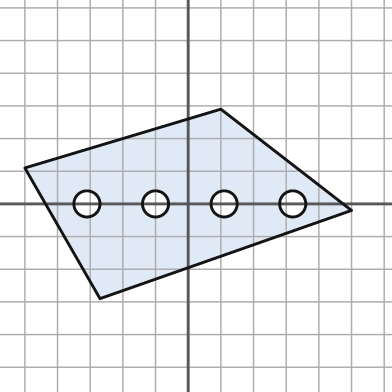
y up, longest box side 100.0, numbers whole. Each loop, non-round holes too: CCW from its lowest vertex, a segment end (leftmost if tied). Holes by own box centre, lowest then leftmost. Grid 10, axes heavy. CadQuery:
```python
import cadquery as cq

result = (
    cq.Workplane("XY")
    .moveTo(-27.0, -29.0)
    .lineTo(50.0, -2.0)
    .lineTo(10.0, 29.0)
    .lineTo(-50.0, 11.0)
    .close()
    .moveTo(-31.0, 0.0)
    .circle(4.0)
    .moveTo(-10.0, 0.0)
    .circle(4.0)
    .moveTo(11.0, 0.0)
    .circle(4.0)
    .moveTo(32.0, 0.0)
    .circle(4.0)
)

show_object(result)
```